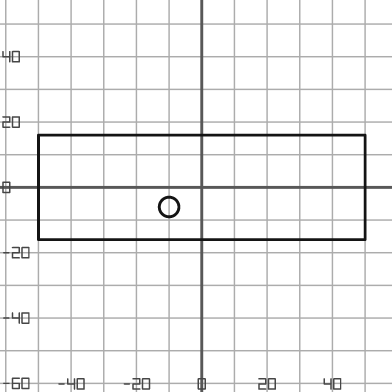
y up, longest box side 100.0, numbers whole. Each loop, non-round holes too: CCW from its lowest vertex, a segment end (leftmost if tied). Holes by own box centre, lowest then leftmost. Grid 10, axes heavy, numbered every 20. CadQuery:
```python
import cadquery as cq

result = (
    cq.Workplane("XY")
    .moveTo(-50.0, -16.0)
    .lineTo(50.0, -16.0)
    .lineTo(50.0, 16.0)
    .lineTo(-50.0, 16.0)
    .close()
    .moveTo(-10.0, -6.0)
    .circle(3.0)
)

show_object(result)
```